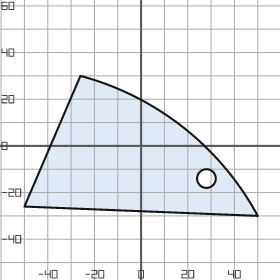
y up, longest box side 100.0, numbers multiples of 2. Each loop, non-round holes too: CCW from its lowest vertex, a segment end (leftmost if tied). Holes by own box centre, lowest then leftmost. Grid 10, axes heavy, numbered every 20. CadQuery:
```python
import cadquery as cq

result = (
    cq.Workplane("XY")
    .moveTo(50.0, -30.0)
    .threePointArc((18.0, 8.0), (-26.0, 30.0))
    .lineTo(-50.0, -26.0)
    .close()
    .moveTo(28.0, -14.0)
    .circle(4.0)
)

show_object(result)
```